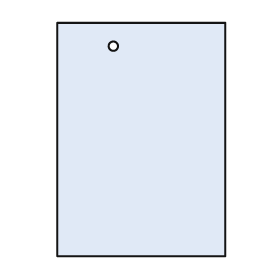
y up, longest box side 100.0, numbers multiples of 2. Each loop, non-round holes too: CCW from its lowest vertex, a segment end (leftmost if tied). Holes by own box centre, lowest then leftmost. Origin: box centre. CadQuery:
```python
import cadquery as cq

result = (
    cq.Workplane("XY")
    .moveTo(-36.0, -50.0)
    .lineTo(36.0, -50.0)
    .lineTo(36.0, 50.0)
    .lineTo(-36.0, 50.0)
    .close()
    .moveTo(-12.0, 40.0)
    .circle(2.0)
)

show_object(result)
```